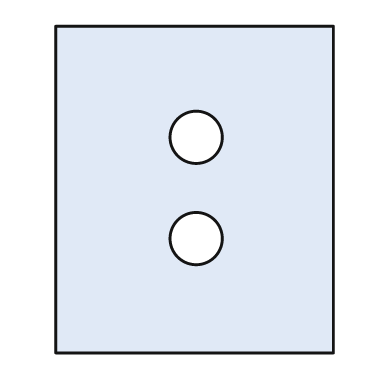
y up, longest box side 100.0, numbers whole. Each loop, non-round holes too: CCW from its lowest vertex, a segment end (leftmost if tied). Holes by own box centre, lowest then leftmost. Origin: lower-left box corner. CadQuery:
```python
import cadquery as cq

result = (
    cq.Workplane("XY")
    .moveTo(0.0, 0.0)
    .lineTo(85.0, 0.0)
    .lineTo(85.0, 100.0)
    .lineTo(0.0, 100.0)
    .close()
    .moveTo(43.0, 35.0)
    .circle(8.0)
    .moveTo(43.0, 66.0)
    .circle(8.0)
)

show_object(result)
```